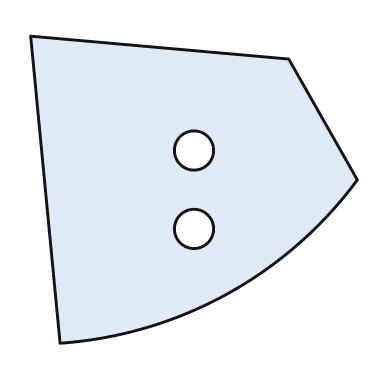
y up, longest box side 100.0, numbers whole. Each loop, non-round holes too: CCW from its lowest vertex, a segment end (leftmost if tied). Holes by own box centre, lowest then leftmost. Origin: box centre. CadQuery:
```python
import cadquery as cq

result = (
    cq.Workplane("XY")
    .moveTo(-41.0, -47.0)
    .threePointArc((10.0, -32.0), (50.0, 3.0))
    .lineTo(29.0, 40.0)
    .lineTo(-50.0, 47.0)
    .close()
    .moveTo(0.0, -12.0)
    .circle(6.0)
    .moveTo(0.0, 12.0)
    .circle(6.0)
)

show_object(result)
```